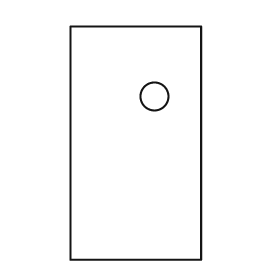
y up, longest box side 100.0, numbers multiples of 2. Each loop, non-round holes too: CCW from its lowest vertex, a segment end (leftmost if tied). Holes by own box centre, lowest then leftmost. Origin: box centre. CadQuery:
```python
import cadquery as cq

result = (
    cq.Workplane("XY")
    .moveTo(-28.0, -50.0)
    .lineTo(28.0, -50.0)
    .lineTo(28.0, 50.0)
    .lineTo(-28.0, 50.0)
    .close()
    .moveTo(8.0, 20.0)
    .circle(6.0)
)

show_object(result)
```